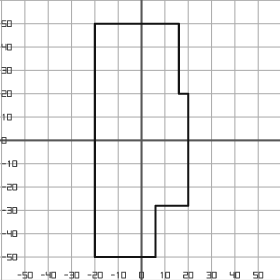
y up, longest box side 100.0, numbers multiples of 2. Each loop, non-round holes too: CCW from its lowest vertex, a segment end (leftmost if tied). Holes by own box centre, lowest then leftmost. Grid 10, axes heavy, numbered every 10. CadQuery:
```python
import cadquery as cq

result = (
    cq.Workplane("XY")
    .moveTo(-20.0, -50.0)
    .lineTo(6.0, -50.0)
    .lineTo(6.0, -28.0)
    .lineTo(20.0, -28.0)
    .lineTo(20.0, 20.0)
    .lineTo(16.0, 20.0)
    .lineTo(16.0, 50.0)
    .lineTo(-20.0, 50.0)
    .close()
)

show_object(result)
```